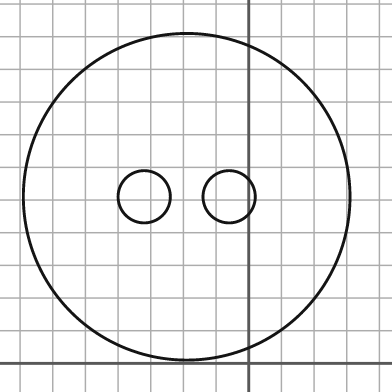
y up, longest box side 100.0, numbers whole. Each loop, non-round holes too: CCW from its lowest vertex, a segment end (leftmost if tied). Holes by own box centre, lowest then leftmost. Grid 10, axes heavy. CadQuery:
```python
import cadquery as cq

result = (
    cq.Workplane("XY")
    .moveTo(-19.0, 51.0)
    .circle(50.0)
    .moveTo(-32.0, 51.0)
    .circle(8.0)
    .moveTo(-6.0, 51.0)
    .circle(8.0)
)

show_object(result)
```